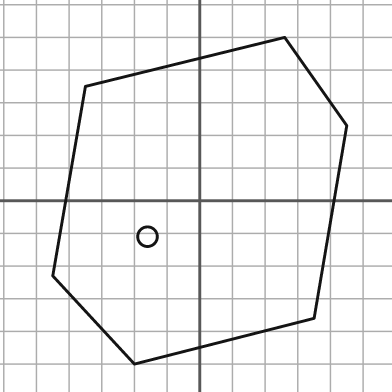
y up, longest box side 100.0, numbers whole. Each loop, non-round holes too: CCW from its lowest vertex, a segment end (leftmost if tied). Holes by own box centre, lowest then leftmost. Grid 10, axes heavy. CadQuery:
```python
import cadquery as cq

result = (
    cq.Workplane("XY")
    .moveTo(-20.0, -50.0)
    .lineTo(35.0, -36.0)
    .lineTo(45.0, 23.0)
    .lineTo(26.0, 50.0)
    .lineTo(-35.0, 35.0)
    .lineTo(-45.0, -23.0)
    .close()
    .moveTo(-16.0, -11.0)
    .circle(3.0)
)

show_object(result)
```